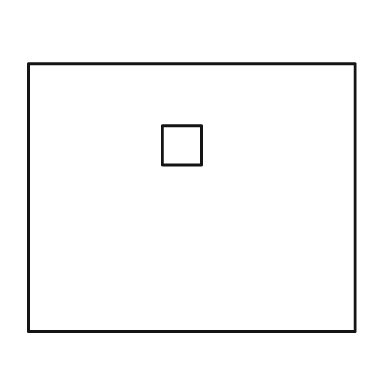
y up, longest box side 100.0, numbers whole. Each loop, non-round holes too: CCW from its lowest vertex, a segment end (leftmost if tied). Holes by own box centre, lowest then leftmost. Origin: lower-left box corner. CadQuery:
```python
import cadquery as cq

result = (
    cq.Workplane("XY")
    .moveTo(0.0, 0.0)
    .lineTo(100.0, 0.0)
    .lineTo(100.0, 82.0)
    .lineTo(0.0, 82.0)
    .close()
    .moveTo(41.0, 51.0)
    .lineTo(53.0, 51.0)
    .lineTo(53.0, 63.0)
    .lineTo(41.0, 63.0)
    .close()
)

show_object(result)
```